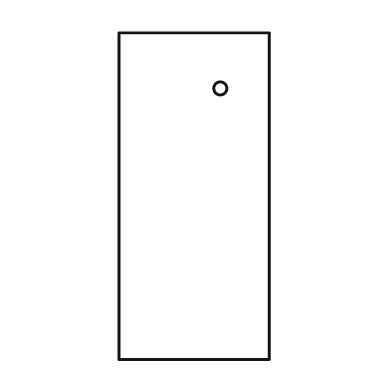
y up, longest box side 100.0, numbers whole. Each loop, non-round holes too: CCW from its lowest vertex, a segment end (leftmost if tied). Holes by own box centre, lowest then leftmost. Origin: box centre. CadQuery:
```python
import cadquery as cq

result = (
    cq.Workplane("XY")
    .moveTo(-23.0, -50.0)
    .lineTo(23.0, -50.0)
    .lineTo(23.0, 50.0)
    .lineTo(-23.0, 50.0)
    .close()
    .moveTo(8.0, 33.0)
    .circle(2.0)
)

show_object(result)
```